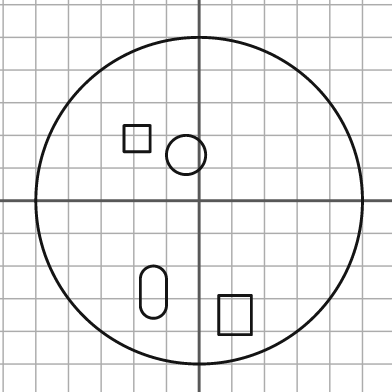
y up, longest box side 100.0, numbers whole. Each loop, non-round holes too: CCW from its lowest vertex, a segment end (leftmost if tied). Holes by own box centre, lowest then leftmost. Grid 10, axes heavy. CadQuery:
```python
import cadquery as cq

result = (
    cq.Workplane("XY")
    .moveTo(0.0, 0.0)
    .circle(50.0)
    .moveTo(6.0, -41.0)
    .lineTo(16.0, -41.0)
    .lineTo(16.0, -29.0)
    .lineTo(6.0, -29.0)
    .close()
    .moveTo(-18.0, -32.0)
    .threePointArc((-14.0, -36.0), (-10.0, -32.0))
    .lineTo(-10.0, -24.0)
    .threePointArc((-14.0, -20.0), (-18.0, -24.0))
    .close()
    .moveTo(-4.0, 14.0)
    .circle(6.0)
    .moveTo(-23.0, 15.0)
    .lineTo(-15.0, 15.0)
    .lineTo(-15.0, 23.0)
    .lineTo(-23.0, 23.0)
    .close()
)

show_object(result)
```